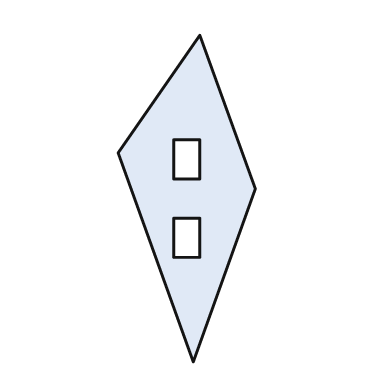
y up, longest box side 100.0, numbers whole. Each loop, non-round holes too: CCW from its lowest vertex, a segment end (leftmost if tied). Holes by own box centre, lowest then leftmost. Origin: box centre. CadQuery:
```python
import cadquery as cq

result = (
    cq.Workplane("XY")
    .moveTo(2.0, -50.0)
    .lineTo(21.0, 3.0)
    .lineTo(4.0, 50.0)
    .lineTo(-21.0, 14.0)
    .close()
    .moveTo(-4.0, -18.0)
    .lineTo(4.0, -18.0)
    .lineTo(4.0, -6.0)
    .lineTo(-4.0, -6.0)
    .close()
    .moveTo(-4.0, 6.0)
    .lineTo(4.0, 6.0)
    .lineTo(4.0, 18.0)
    .lineTo(-4.0, 18.0)
    .close()
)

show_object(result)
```